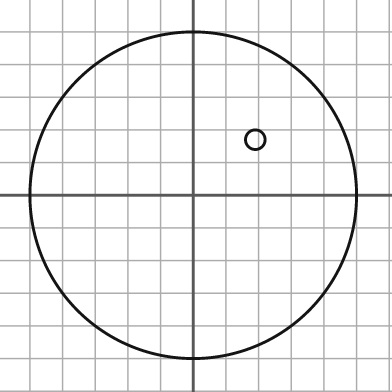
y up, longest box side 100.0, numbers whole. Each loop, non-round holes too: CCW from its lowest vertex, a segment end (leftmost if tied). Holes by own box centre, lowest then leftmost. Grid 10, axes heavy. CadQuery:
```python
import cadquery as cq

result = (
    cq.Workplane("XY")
    .moveTo(0.0, 0.0)
    .circle(50.0)
    .moveTo(19.0, 17.0)
    .circle(3.0)
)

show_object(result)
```